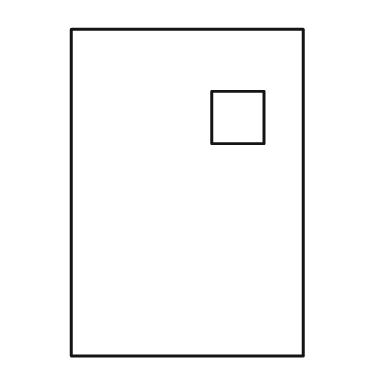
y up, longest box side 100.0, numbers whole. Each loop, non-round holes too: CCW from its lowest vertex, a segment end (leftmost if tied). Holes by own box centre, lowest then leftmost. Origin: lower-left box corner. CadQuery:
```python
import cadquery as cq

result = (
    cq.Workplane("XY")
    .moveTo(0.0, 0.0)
    .lineTo(71.0, 0.0)
    .lineTo(71.0, 100.0)
    .lineTo(0.0, 100.0)
    .close()
    .moveTo(43.0, 65.0)
    .lineTo(59.0, 65.0)
    .lineTo(59.0, 81.0)
    .lineTo(43.0, 81.0)
    .close()
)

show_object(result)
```